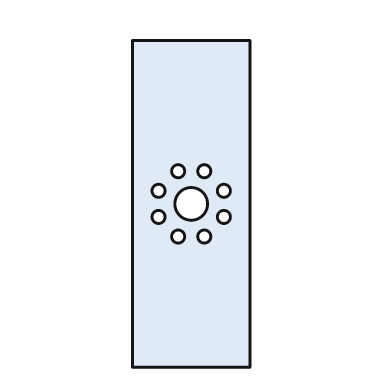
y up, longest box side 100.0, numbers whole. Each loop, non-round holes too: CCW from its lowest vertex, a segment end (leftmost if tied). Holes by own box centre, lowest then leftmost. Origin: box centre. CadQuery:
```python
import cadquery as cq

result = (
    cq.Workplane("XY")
    .moveTo(-18.0, -50.0)
    .lineTo(18.0, -50.0)
    .lineTo(18.0, 50.0)
    .lineTo(-18.0, 50.0)
    .close()
    .moveTo(-4.0, -10.0)
    .circle(2.0)
    .moveTo(4.0, -10.0)
    .circle(2.0)
    .moveTo(-10.0, -4.0)
    .circle(2.0)
    .moveTo(10.0, -4.0)
    .circle(2.0)
    .moveTo(0.0, 0.0)
    .circle(5.0)
    .moveTo(-10.0, 4.0)
    .circle(2.0)
    .moveTo(10.0, 4.0)
    .circle(2.0)
    .moveTo(-4.0, 10.0)
    .circle(2.0)
    .moveTo(4.0, 10.0)
    .circle(2.0)
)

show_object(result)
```